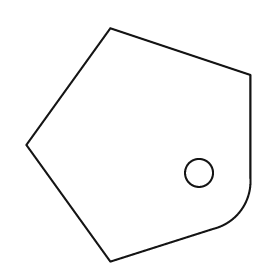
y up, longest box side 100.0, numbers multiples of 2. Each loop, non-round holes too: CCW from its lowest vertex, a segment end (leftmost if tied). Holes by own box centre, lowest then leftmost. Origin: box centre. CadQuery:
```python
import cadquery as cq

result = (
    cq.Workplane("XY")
    .moveTo(-12.0, -50.0)
    .lineTo(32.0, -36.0)
    .threePointArc((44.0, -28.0), (48.0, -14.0))
    .lineTo(48.0, 30.0)
    .lineTo(-12.0, 50.0)
    .lineTo(-48.0, 0.0)
    .close()
    .moveTo(26.0, -12.0)
    .circle(6.0)
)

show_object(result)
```